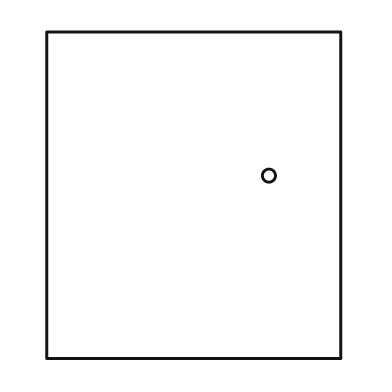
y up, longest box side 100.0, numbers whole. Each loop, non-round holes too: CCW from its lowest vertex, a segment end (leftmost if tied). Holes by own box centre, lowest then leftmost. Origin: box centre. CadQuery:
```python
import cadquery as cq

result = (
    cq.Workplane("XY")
    .moveTo(-45.0, -50.0)
    .lineTo(45.0, -50.0)
    .lineTo(45.0, 50.0)
    .lineTo(-45.0, 50.0)
    .close()
    .moveTo(23.0, 6.0)
    .circle(2.0)
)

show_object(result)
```